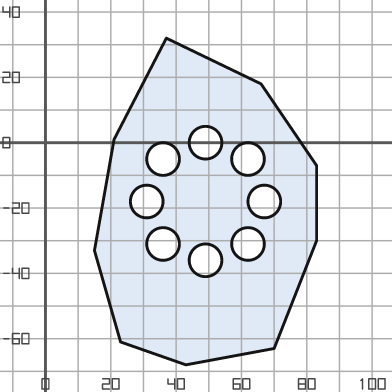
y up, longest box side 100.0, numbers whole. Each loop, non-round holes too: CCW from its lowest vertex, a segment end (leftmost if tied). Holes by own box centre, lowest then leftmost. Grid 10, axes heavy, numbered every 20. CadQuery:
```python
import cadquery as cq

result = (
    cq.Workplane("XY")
    .moveTo(43.0, -68.0)
    .lineTo(70.0, -63.0)
    .lineTo(83.0, -30.0)
    .lineTo(83.0, -7.0)
    .lineTo(66.0, 18.0)
    .lineTo(37.0, 32.0)
    .lineTo(21.0, 1.0)
    .lineTo(15.0, -33.0)
    .lineTo(23.0, -61.0)
    .close()
    .moveTo(49.0, -36.0)
    .circle(5.0)
    .moveTo(36.0, -31.0)
    .circle(5.0)
    .moveTo(62.0, -31.0)
    .circle(5.0)
    .moveTo(31.0, -18.0)
    .circle(5.0)
    .moveTo(67.0, -18.0)
    .circle(5.0)
    .moveTo(36.0, -5.0)
    .circle(5.0)
    .moveTo(62.0, -5.0)
    .circle(5.0)
    .moveTo(49.0, 0.0)
    .circle(5.0)
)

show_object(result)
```